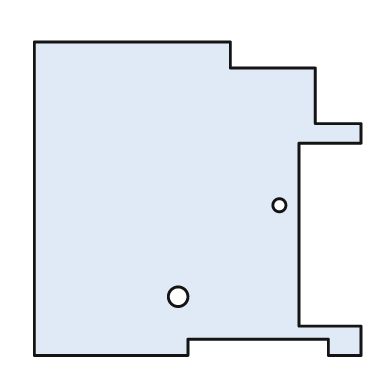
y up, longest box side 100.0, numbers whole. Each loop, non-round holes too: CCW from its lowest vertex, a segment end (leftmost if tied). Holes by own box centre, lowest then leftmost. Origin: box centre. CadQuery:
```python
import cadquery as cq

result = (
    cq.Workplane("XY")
    .moveTo(-50.0, -48.0)
    .lineTo(-3.0, -48.0)
    .lineTo(-3.0, -43.0)
    .lineTo(40.0, -43.0)
    .lineTo(40.0, -48.0)
    .lineTo(50.0, -48.0)
    .lineTo(50.0, -39.0)
    .lineTo(31.0, -39.0)
    .lineTo(31.0, 17.0)
    .lineTo(50.0, 17.0)
    .lineTo(50.0, 23.0)
    .lineTo(36.0, 23.0)
    .lineTo(36.0, 40.0)
    .lineTo(10.0, 40.0)
    .lineTo(10.0, 48.0)
    .lineTo(-50.0, 48.0)
    .close()
    .moveTo(-6.0, -30.0)
    .circle(3.0)
    .moveTo(25.0, -2.0)
    .circle(2.0)
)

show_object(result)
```